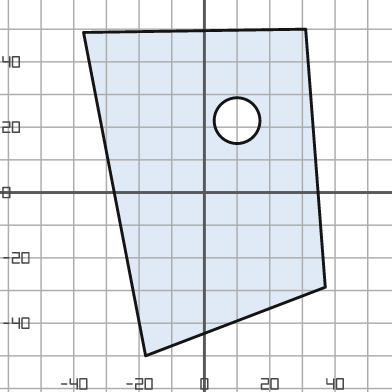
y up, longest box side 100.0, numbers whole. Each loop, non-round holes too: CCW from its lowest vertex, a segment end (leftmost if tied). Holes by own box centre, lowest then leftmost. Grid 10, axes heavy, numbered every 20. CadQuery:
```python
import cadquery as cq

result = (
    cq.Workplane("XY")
    .moveTo(-18.0, -50.0)
    .lineTo(37.0, -29.0)
    .lineTo(31.0, 50.0)
    .lineTo(-37.0, 49.0)
    .close()
    .moveTo(10.0, 22.0)
    .circle(7.0)
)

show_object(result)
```